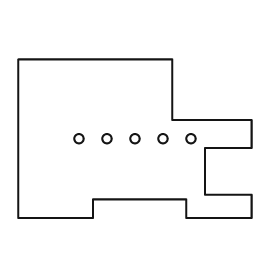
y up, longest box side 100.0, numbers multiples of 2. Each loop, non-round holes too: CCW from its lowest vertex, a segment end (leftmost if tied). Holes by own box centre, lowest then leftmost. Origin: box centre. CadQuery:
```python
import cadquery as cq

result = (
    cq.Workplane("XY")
    .moveTo(-50.0, -34.0)
    .lineTo(-18.0, -34.0)
    .lineTo(-18.0, -26.0)
    .lineTo(22.0, -26.0)
    .lineTo(22.0, -34.0)
    .lineTo(50.0, -34.0)
    .lineTo(50.0, -24.0)
    .lineTo(30.0, -24.0)
    .lineTo(30.0, -4.0)
    .lineTo(50.0, -4.0)
    .lineTo(50.0, 8.0)
    .lineTo(16.0, 8.0)
    .lineTo(16.0, 34.0)
    .lineTo(-50.0, 34.0)
    .close()
    .moveTo(-24.0, 0.0)
    .circle(2.0)
    .moveTo(-12.0, 0.0)
    .circle(2.0)
    .moveTo(0.0, 0.0)
    .circle(2.0)
    .moveTo(12.0, 0.0)
    .circle(2.0)
    .moveTo(24.0, 0.0)
    .circle(2.0)
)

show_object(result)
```